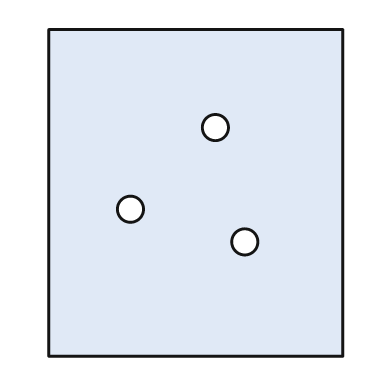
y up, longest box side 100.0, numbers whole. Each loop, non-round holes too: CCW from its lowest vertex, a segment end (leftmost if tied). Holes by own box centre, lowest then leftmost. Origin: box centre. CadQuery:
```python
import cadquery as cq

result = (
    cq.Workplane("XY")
    .moveTo(-45.0, -50.0)
    .lineTo(45.0, -50.0)
    .lineTo(45.0, 50.0)
    .lineTo(-45.0, 50.0)
    .close()
    .moveTo(15.0, -15.0)
    .circle(4.0)
    .moveTo(-20.0, -5.0)
    .circle(4.0)
    .moveTo(6.0, 20.0)
    .circle(4.0)
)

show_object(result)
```